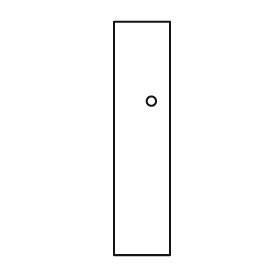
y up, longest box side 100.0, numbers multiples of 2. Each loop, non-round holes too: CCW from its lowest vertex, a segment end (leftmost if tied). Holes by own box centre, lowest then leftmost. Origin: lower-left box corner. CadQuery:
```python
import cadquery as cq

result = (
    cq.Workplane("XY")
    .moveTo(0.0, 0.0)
    .lineTo(24.0, 0.0)
    .lineTo(24.0, 100.0)
    .lineTo(0.0, 100.0)
    .close()
    .moveTo(16.0, 66.0)
    .circle(2.0)
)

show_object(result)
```